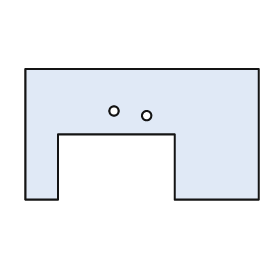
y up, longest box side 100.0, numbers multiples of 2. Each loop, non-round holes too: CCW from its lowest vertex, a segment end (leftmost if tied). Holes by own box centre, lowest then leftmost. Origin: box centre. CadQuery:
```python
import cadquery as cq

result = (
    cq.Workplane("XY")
    .moveTo(-50.0, -28.0)
    .lineTo(-36.0, -28.0)
    .lineTo(-36.0, 0.0)
    .lineTo(14.0, 0.0)
    .lineTo(14.0, -28.0)
    .lineTo(50.0, -28.0)
    .lineTo(50.0, 28.0)
    .lineTo(-50.0, 28.0)
    .close()
    .moveTo(2.0, 8.0)
    .circle(2.0)
    .moveTo(-12.0, 10.0)
    .circle(2.0)
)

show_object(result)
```